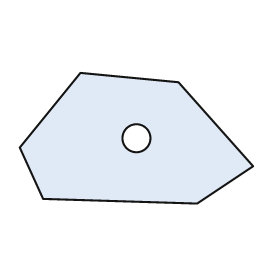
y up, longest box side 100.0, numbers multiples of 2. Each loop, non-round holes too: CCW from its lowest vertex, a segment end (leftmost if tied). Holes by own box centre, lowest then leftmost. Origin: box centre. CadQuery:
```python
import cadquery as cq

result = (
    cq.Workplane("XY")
    .moveTo(26.0, -28.0)
    .lineTo(50.0, -12.0)
    .lineTo(18.0, 24.0)
    .lineTo(-24.0, 28.0)
    .lineTo(-50.0, -4.0)
    .lineTo(-40.0, -26.0)
    .close()
    .moveTo(0.0, 0.0)
    .circle(6.0)
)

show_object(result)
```